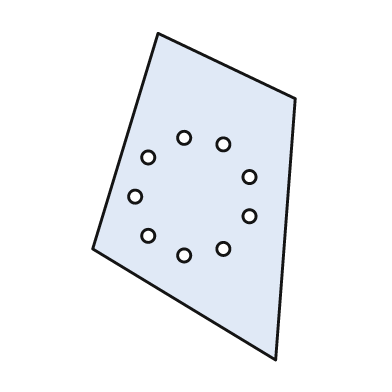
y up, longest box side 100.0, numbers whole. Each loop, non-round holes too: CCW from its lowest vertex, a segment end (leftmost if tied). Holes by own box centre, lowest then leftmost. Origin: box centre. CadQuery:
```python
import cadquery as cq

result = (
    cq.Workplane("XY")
    .moveTo(25.0, -50.0)
    .lineTo(31.0, 30.0)
    .lineTo(-11.0, 50.0)
    .lineTo(-31.0, -16.0)
    .close()
    .moveTo(-3.0, -18.0)
    .circle(2.0)
    .moveTo(9.0, -16.0)
    .circle(2.0)
    .moveTo(-14.0, -12.0)
    .circle(2.0)
    .moveTo(17.0, -6.0)
    .circle(2.0)
    .moveTo(-18.0, 0.0)
    .circle(2.0)
    .moveTo(17.0, 6.0)
    .circle(2.0)
    .moveTo(-14.0, 12.0)
    .circle(2.0)
    .moveTo(9.0, 16.0)
    .circle(2.0)
    .moveTo(-3.0, 18.0)
    .circle(2.0)
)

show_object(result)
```